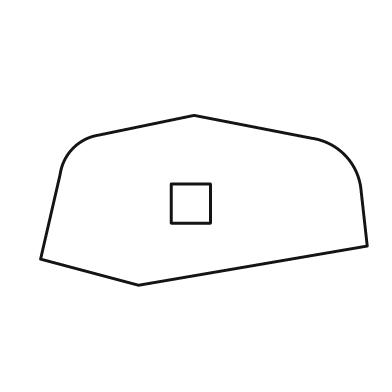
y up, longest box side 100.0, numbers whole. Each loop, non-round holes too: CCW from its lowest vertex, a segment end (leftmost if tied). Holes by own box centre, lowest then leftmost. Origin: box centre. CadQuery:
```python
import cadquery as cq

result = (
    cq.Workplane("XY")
    .moveTo(-20.0, -26.0)
    .lineTo(50.0, -14.0)
    .lineTo(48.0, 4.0)
    .threePointArc((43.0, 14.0), (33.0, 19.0))
    .lineTo(-3.0, 26.0)
    .lineTo(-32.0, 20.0)
    .threePointArc((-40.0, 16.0), (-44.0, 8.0))
    .lineTo(-50.0, -18.0)
    .close()
    .moveTo(-10.0, -7.0)
    .lineTo(2.0, -7.0)
    .lineTo(2.0, 5.0)
    .lineTo(-10.0, 5.0)
    .close()
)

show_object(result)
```